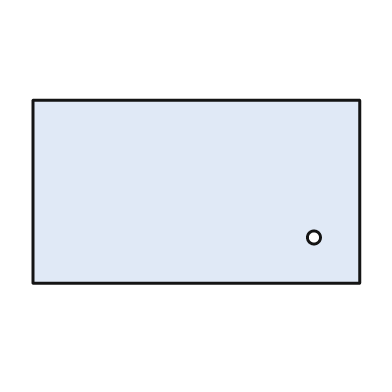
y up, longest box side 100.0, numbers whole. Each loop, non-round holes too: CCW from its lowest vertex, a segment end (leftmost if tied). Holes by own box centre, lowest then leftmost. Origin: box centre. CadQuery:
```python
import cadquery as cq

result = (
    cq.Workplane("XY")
    .moveTo(-50.0, -28.0)
    .lineTo(50.0, -28.0)
    .lineTo(50.0, 28.0)
    .lineTo(-50.0, 28.0)
    .close()
    .moveTo(36.0, -14.0)
    .circle(2.0)
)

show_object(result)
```